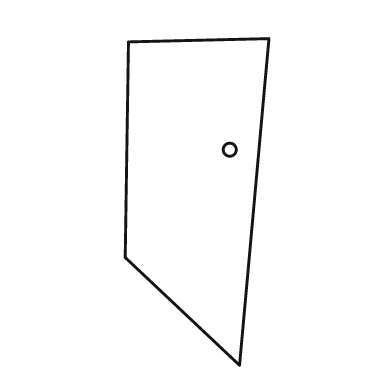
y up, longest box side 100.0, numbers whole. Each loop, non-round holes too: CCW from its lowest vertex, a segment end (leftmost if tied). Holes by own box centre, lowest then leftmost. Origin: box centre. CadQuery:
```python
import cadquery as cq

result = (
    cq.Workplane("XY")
    .moveTo(13.0, -50.0)
    .lineTo(22.0, 50.0)
    .lineTo(-21.0, 49.0)
    .lineTo(-22.0, -17.0)
    .close()
    .moveTo(10.0, 16.0)
    .circle(2.0)
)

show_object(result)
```